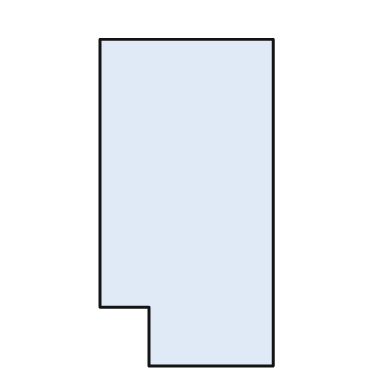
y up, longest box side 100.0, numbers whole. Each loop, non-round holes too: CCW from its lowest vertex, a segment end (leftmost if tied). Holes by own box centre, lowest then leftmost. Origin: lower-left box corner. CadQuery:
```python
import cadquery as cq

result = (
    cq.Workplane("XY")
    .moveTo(15.0, 0.0)
    .lineTo(53.0, 0.0)
    .lineTo(53.0, 100.0)
    .lineTo(0.0, 100.0)
    .lineTo(0.0, 18.0)
    .lineTo(15.0, 18.0)
    .close()
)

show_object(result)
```